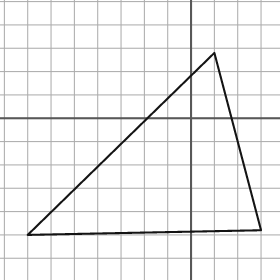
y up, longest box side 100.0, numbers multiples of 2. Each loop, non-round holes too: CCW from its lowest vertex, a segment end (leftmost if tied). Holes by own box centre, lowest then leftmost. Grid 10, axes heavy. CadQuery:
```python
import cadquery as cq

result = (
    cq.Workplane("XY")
    .moveTo(-70.0, -50.0)
    .lineTo(30.0, -48.0)
    .lineTo(10.0, 28.0)
    .close()
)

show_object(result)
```